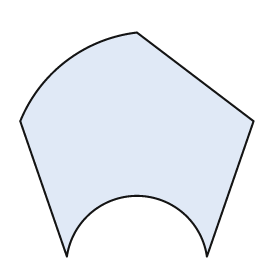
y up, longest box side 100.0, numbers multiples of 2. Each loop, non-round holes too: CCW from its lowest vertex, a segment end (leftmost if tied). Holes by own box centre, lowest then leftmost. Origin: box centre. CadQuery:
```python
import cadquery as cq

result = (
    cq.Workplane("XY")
    .moveTo(-30.0, -48.0)
    .threePointArc((0.0, -22.0), (30.0, -48.0))
    .lineTo(50.0, 10.0)
    .lineTo(0.0, 48.0)
    .threePointArc((-30.0, 36.0), (-50.0, 10.0))
    .close()
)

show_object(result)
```